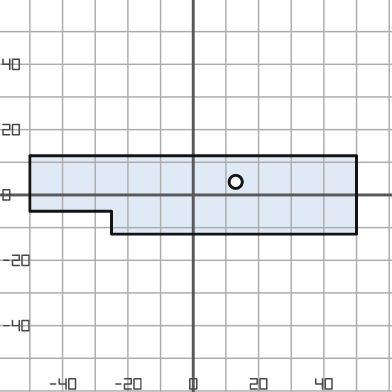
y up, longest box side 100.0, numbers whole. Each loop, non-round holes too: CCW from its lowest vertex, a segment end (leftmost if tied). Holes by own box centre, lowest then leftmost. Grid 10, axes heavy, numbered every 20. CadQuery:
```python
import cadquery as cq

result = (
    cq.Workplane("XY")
    .moveTo(-25.0, -12.0)
    .lineTo(50.0, -12.0)
    .lineTo(50.0, 12.0)
    .lineTo(-50.0, 12.0)
    .lineTo(-50.0, -5.0)
    .lineTo(-25.0, -5.0)
    .close()
    .moveTo(13.0, 4.0)
    .circle(2.0)
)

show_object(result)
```